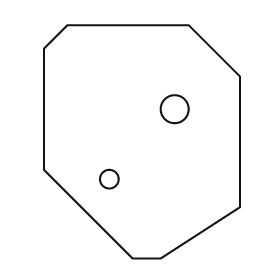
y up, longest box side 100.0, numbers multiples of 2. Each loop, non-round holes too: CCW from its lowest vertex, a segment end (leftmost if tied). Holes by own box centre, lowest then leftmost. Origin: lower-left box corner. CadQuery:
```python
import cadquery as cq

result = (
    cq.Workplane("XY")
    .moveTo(38.0, 0.0)
    .lineTo(50.0, 0.0)
    .lineTo(84.0, 22.0)
    .lineTo(84.0, 78.0)
    .lineTo(62.0, 100.0)
    .lineTo(10.0, 100.0)
    .lineTo(0.0, 90.0)
    .lineTo(0.0, 38.0)
    .close()
    .moveTo(28.0, 34.0)
    .circle(4.0)
    .moveTo(56.0, 64.0)
    .circle(6.0)
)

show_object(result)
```